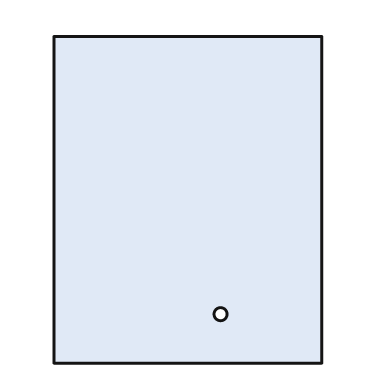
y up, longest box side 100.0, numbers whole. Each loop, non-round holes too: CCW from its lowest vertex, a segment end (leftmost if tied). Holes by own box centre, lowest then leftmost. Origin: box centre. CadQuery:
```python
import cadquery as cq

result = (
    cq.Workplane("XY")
    .moveTo(-41.0, -50.0)
    .lineTo(41.0, -50.0)
    .lineTo(41.0, 50.0)
    .lineTo(-41.0, 50.0)
    .close()
    .moveTo(10.0, -35.0)
    .circle(2.0)
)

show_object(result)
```